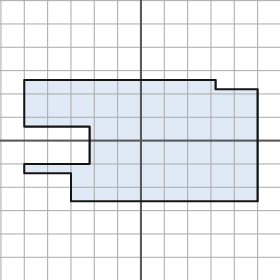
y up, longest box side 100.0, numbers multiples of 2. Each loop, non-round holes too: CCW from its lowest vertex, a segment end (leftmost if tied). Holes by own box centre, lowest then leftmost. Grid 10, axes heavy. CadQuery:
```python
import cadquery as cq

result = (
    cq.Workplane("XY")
    .moveTo(-30.0, -26.0)
    .lineTo(50.0, -26.0)
    .lineTo(50.0, 22.0)
    .lineTo(32.0, 22.0)
    .lineTo(32.0, 26.0)
    .lineTo(-50.0, 26.0)
    .lineTo(-50.0, 6.0)
    .lineTo(-22.0, 6.0)
    .lineTo(-22.0, -10.0)
    .lineTo(-50.0, -10.0)
    .lineTo(-50.0, -14.0)
    .lineTo(-30.0, -14.0)
    .close()
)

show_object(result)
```